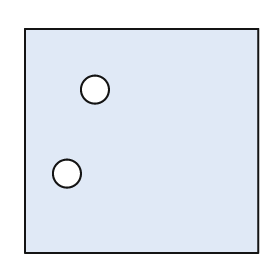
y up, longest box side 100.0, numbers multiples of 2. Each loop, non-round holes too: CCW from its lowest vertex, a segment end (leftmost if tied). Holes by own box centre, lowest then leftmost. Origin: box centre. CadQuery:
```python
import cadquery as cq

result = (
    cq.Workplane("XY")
    .moveTo(-50.0, -48.0)
    .lineTo(50.0, -48.0)
    .lineTo(50.0, 48.0)
    .lineTo(-50.0, 48.0)
    .close()
    .moveTo(-32.0, -14.0)
    .circle(6.0)
    .moveTo(-20.0, 22.0)
    .circle(6.0)
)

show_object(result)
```